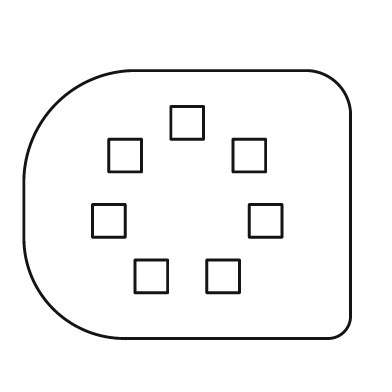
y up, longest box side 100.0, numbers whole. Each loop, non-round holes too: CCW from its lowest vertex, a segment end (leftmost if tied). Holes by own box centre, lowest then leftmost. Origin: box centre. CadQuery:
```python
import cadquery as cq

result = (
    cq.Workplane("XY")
    .moveTo(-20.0, -41.0)
    .lineTo(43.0, -41.0)
    .threePointArc((48.0, -39.0), (50.0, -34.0))
    .lineTo(50.0, 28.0)
    .threePointArc((46.0, 37.0), (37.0, 41.0))
    .lineTo(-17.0, 41.0)
    .threePointArc((-40.0, 31.0), (-50.0, 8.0))
    .lineTo(-50.0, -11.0)
    .threePointArc((-41.0, -32.0), (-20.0, -41.0))
    .close()
    .moveTo(-16.0, -27.0)
    .lineTo(-6.0, -27.0)
    .lineTo(-6.0, -17.0)
    .lineTo(-16.0, -17.0)
    .close()
    .moveTo(6.0, -27.0)
    .lineTo(16.0, -27.0)
    .lineTo(16.0, -17.0)
    .lineTo(6.0, -17.0)
    .close()
    .moveTo(-29.0, -10.0)
    .lineTo(-19.0, -10.0)
    .lineTo(-19.0, 0.0)
    .lineTo(-29.0, 0.0)
    .close()
    .moveTo(19.0, -10.0)
    .lineTo(29.0, -10.0)
    .lineTo(29.0, 0.0)
    .lineTo(19.0, 0.0)
    .close()
    .moveTo(-24.0, 10.0)
    .lineTo(-14.0, 10.0)
    .lineTo(-14.0, 20.0)
    .lineTo(-24.0, 20.0)
    .close()
    .moveTo(14.0, 10.0)
    .lineTo(24.0, 10.0)
    .lineTo(24.0, 20.0)
    .lineTo(14.0, 20.0)
    .close()
    .moveTo(-5.0, 20.0)
    .lineTo(5.0, 20.0)
    .lineTo(5.0, 30.0)
    .lineTo(-5.0, 30.0)
    .close()
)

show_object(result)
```